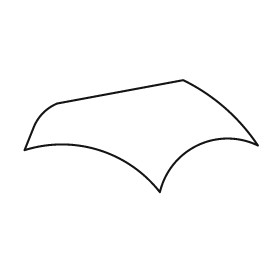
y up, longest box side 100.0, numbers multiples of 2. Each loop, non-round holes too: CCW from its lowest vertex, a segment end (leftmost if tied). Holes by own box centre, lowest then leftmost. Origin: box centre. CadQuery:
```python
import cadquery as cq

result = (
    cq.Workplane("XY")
    .moveTo(8.0, -24.0)
    .threePointArc((24.0, -4.0), (50.0, -4.0))
    .threePointArc((36.0, 12.0), (18.0, 24.0))
    .lineTo(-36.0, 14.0)
    .threePointArc((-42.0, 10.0), (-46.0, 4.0))
    .lineTo(-50.0, -6.0)
    .threePointArc((-18.0, -6.0), (8.0, -24.0))
    .close()
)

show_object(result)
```